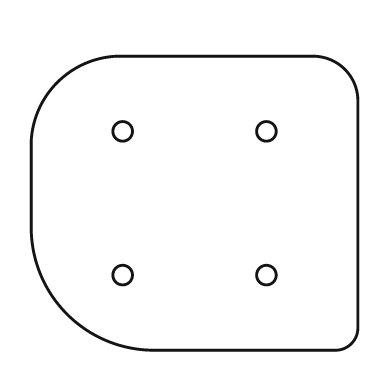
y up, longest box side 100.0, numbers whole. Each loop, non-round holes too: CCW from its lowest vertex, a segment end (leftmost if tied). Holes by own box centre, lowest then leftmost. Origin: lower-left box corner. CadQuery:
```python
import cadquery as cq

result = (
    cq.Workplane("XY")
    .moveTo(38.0, 0.0)
    .lineTo(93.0, 0.0)
    .threePointArc((98.0, 2.0), (100.0, 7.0))
    .lineTo(100.0, 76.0)
    .threePointArc((96.0, 86.0), (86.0, 90.0))
    .lineTo(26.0, 90.0)
    .threePointArc((8.0, 82.0), (0.0, 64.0))
    .lineTo(0.0, 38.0)
    .threePointArc((11.0, 11.0), (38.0, 0.0))
    .close()
    .moveTo(28.0, 23.0)
    .circle(3.0)
    .moveTo(72.0, 23.0)
    .circle(3.0)
    .moveTo(28.0, 67.0)
    .circle(3.0)
    .moveTo(72.0, 67.0)
    .circle(3.0)
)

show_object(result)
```